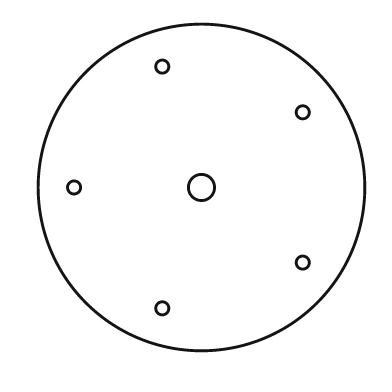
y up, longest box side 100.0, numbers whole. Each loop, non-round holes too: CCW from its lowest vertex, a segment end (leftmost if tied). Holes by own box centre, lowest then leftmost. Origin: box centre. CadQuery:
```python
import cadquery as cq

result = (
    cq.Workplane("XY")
    .moveTo(0.0, 0.0)
    .circle(50.0)
    .moveTo(-12.0, -37.0)
    .circle(2.0)
    .moveTo(31.0, -23.0)
    .circle(2.0)
    .moveTo(-39.0, 0.0)
    .circle(2.0)
    .moveTo(0.0, 0.0)
    .circle(4.0)
    .moveTo(31.0, 23.0)
    .circle(2.0)
    .moveTo(-12.0, 37.0)
    .circle(2.0)
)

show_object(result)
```